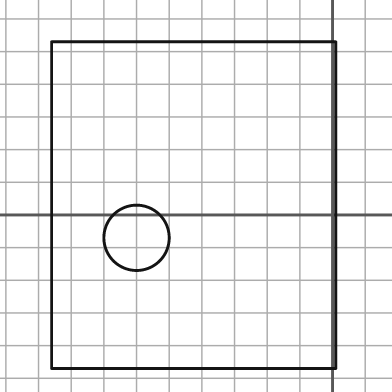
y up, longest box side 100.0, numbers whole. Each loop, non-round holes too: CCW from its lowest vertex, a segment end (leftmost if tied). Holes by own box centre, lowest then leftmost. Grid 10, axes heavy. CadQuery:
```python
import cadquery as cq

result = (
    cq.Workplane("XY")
    .moveTo(-86.0, -47.0)
    .lineTo(1.0, -47.0)
    .lineTo(1.0, 53.0)
    .lineTo(-86.0, 53.0)
    .close()
    .moveTo(-60.0, -7.0)
    .circle(10.0)
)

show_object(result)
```